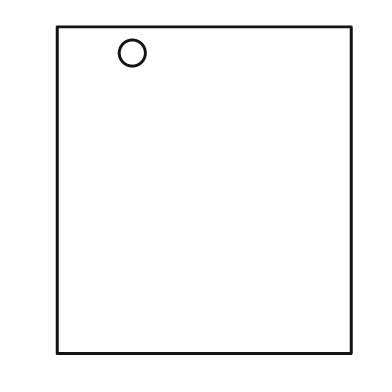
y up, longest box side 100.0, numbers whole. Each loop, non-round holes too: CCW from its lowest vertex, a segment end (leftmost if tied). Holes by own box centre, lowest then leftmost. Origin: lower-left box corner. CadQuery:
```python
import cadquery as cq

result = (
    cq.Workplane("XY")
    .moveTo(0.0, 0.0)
    .lineTo(90.0, 0.0)
    .lineTo(90.0, 100.0)
    .lineTo(0.0, 100.0)
    .close()
    .moveTo(23.0, 92.0)
    .circle(4.0)
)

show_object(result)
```